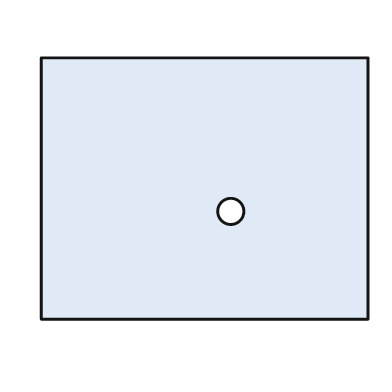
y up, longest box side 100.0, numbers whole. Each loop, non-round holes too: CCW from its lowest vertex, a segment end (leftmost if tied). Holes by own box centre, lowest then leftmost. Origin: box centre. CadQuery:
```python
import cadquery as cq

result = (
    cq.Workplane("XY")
    .moveTo(-50.0, -40.0)
    .lineTo(50.0, -40.0)
    .lineTo(50.0, 40.0)
    .lineTo(-50.0, 40.0)
    .close()
    .moveTo(8.0, -7.0)
    .circle(4.0)
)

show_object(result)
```